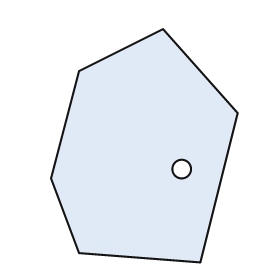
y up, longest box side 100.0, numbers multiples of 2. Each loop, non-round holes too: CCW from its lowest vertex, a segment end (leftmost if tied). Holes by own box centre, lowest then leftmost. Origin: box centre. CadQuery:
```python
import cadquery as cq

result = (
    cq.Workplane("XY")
    .moveTo(24.0, -50.0)
    .lineTo(40.0, 14.0)
    .lineTo(8.0, 50.0)
    .lineTo(-28.0, 32.0)
    .lineTo(-40.0, -14.0)
    .lineTo(-28.0, -46.0)
    .close()
    .moveTo(16.0, -10.0)
    .circle(4.0)
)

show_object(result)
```